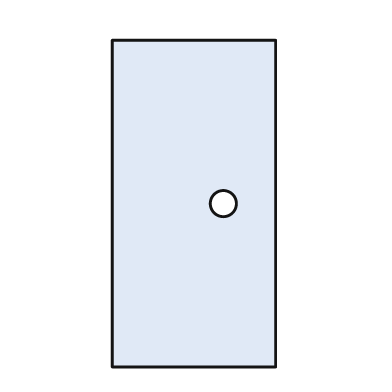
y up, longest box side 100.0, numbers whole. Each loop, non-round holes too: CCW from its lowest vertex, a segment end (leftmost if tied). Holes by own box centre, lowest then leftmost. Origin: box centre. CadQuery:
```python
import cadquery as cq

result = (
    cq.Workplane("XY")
    .moveTo(-25.0, -50.0)
    .lineTo(25.0, -50.0)
    .lineTo(25.0, 50.0)
    .lineTo(-25.0, 50.0)
    .close()
    .moveTo(9.0, 0.0)
    .circle(4.0)
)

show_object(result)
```